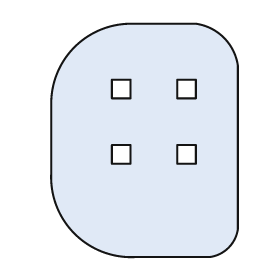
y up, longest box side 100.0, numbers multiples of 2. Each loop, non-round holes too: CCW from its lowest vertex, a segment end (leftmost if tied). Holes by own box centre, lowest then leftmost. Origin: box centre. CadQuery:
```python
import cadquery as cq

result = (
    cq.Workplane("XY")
    .moveTo(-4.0, -50.0)
    .lineTo(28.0, -50.0)
    .threePointArc((36.0, -46.0), (40.0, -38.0))
    .lineTo(40.0, 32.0)
    .threePointArc((34.0, 44.0), (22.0, 50.0))
    .lineTo(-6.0, 50.0)
    .threePointArc((-30.0, 40.0), (-40.0, 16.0))
    .lineTo(-40.0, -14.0)
    .threePointArc((-30.0, -40.0), (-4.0, -50.0))
    .close()
    .moveTo(-14.0, -10.0)
    .lineTo(-6.0, -10.0)
    .lineTo(-6.0, -2.0)
    .lineTo(-14.0, -2.0)
    .close()
    .moveTo(14.0, -10.0)
    .lineTo(22.0, -10.0)
    .lineTo(22.0, -2.0)
    .lineTo(14.0, -2.0)
    .close()
    .moveTo(-14.0, 18.0)
    .lineTo(-6.0, 18.0)
    .lineTo(-6.0, 26.0)
    .lineTo(-14.0, 26.0)
    .close()
    .moveTo(14.0, 18.0)
    .lineTo(22.0, 18.0)
    .lineTo(22.0, 26.0)
    .lineTo(14.0, 26.0)
    .close()
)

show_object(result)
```